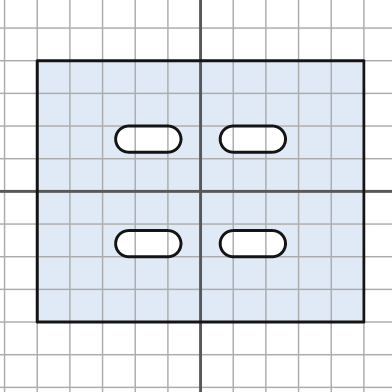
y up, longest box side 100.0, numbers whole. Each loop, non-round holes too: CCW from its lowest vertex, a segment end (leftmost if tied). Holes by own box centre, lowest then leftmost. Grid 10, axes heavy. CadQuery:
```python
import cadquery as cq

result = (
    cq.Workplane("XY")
    .moveTo(-50.0, -40.0)
    .lineTo(50.0, -40.0)
    .lineTo(50.0, 40.0)
    .lineTo(-50.0, 40.0)
    .close()
    .moveTo(-22.0, -20.0)
    .lineTo(-10.0, -20.0)
    .threePointArc((-6.0, -16.0), (-10.0, -12.0))
    .lineTo(-22.0, -12.0)
    .threePointArc((-26.0, -16.0), (-22.0, -20.0))
    .close()
    .moveTo(10.0, -20.0)
    .lineTo(22.0, -20.0)
    .threePointArc((26.0, -16.0), (22.0, -12.0))
    .lineTo(10.0, -12.0)
    .threePointArc((6.0, -16.0), (10.0, -20.0))
    .close()
    .moveTo(-22.0, 12.0)
    .lineTo(-10.0, 12.0)
    .threePointArc((-6.0, 16.0), (-10.0, 20.0))
    .lineTo(-22.0, 20.0)
    .threePointArc((-26.0, 16.0), (-22.0, 12.0))
    .close()
    .moveTo(10.0, 12.0)
    .lineTo(22.0, 12.0)
    .threePointArc((26.0, 16.0), (22.0, 20.0))
    .lineTo(10.0, 20.0)
    .threePointArc((6.0, 16.0), (10.0, 12.0))
    .close()
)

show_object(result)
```